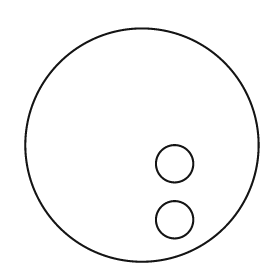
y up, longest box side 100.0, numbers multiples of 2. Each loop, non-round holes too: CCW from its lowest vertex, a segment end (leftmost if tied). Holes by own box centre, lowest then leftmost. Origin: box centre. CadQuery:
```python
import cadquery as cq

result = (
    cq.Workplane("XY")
    .moveTo(0.0, 0.0)
    .circle(50.0)
    .moveTo(14.0, -32.0)
    .circle(8.0)
    .moveTo(14.0, -8.0)
    .circle(8.0)
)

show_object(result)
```